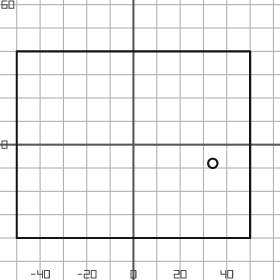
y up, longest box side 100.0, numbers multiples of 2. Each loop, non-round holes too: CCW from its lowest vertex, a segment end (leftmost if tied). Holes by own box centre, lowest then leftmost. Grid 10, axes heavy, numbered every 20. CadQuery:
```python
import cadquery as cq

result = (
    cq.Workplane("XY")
    .moveTo(-50.0, -40.0)
    .lineTo(50.0, -40.0)
    .lineTo(50.0, 40.0)
    .lineTo(-50.0, 40.0)
    .close()
    .moveTo(34.0, -8.0)
    .circle(2.0)
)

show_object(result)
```